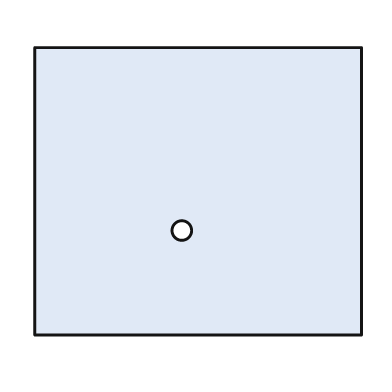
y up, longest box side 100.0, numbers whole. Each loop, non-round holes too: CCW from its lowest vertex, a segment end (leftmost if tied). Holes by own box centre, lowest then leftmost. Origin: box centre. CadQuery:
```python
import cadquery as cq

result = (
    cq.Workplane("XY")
    .moveTo(-50.0, -44.0)
    .lineTo(50.0, -44.0)
    .lineTo(50.0, 44.0)
    .lineTo(-50.0, 44.0)
    .close()
    .moveTo(-5.0, -12.0)
    .circle(3.0)
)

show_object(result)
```